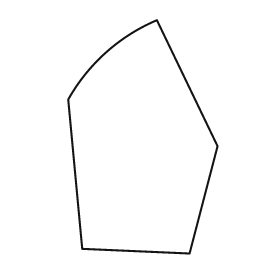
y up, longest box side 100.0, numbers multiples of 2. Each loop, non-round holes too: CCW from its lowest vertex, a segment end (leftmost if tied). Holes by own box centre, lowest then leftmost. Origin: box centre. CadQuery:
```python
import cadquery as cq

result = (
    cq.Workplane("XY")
    .moveTo(20.0, -50.0)
    .lineTo(32.0, -4.0)
    .lineTo(6.0, 50.0)
    .threePointArc((-16.0, 36.0), (-32.0, 16.0))
    .lineTo(-26.0, -48.0)
    .close()
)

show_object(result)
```